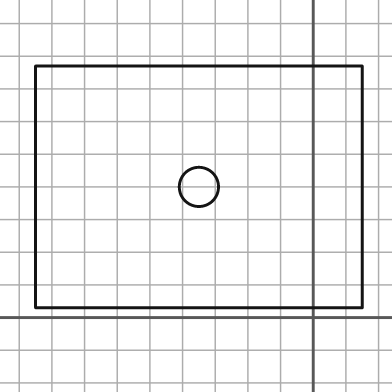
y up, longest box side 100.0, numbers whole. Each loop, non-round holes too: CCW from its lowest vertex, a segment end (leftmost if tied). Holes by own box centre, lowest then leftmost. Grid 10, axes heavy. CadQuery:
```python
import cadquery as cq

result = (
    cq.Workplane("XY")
    .moveTo(-85.0, 3.0)
    .lineTo(15.0, 3.0)
    .lineTo(15.0, 77.0)
    .lineTo(-85.0, 77.0)
    .close()
    .moveTo(-35.0, 40.0)
    .circle(6.0)
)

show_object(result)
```